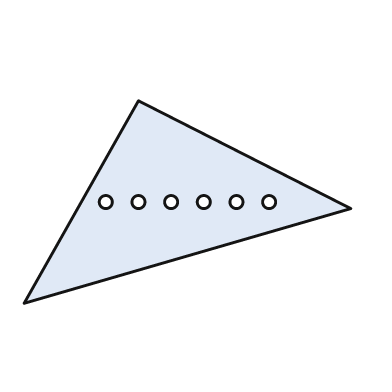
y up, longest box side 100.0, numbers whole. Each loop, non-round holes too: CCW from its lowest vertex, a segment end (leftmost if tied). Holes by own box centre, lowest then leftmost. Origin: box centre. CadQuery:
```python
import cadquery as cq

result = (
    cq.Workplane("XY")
    .moveTo(-50.0, -31.0)
    .lineTo(50.0, -2.0)
    .lineTo(-15.0, 31.0)
    .close()
    .moveTo(-25.0, 0.0)
    .circle(2.0)
    .moveTo(-15.0, 0.0)
    .circle(2.0)
    .moveTo(-5.0, 0.0)
    .circle(2.0)
    .moveTo(5.0, 0.0)
    .circle(2.0)
    .moveTo(15.0, 0.0)
    .circle(2.0)
    .moveTo(25.0, 0.0)
    .circle(2.0)
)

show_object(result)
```